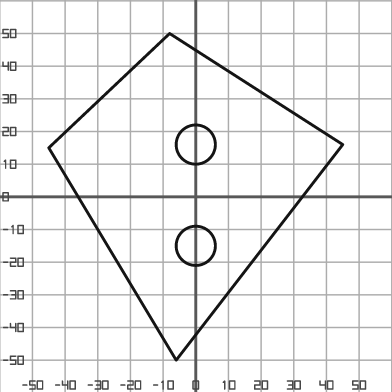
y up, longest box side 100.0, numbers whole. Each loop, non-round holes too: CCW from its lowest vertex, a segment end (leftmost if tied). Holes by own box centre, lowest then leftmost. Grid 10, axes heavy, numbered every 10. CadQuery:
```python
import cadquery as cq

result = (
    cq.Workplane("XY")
    .moveTo(-6.0, -50.0)
    .lineTo(45.0, 16.0)
    .lineTo(-8.0, 50.0)
    .lineTo(-45.0, 15.0)
    .close()
    .moveTo(0.0, -15.0)
    .circle(6.0)
    .moveTo(0.0, 16.0)
    .circle(6.0)
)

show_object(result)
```